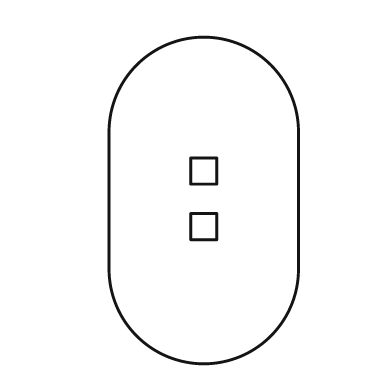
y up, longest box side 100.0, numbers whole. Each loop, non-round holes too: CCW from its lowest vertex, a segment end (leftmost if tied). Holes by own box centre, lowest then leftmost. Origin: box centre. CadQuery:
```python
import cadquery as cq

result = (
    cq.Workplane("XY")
    .moveTo(-29.0, -21.0)
    .threePointArc((0.0, -50.0), (29.0, -21.0))
    .lineTo(29.0, 21.0)
    .threePointArc((0.0, 50.0), (-29.0, 21.0))
    .close()
    .moveTo(-4.0, -12.0)
    .lineTo(4.0, -12.0)
    .lineTo(4.0, -4.0)
    .lineTo(-4.0, -4.0)
    .close()
    .moveTo(-4.0, 5.0)
    .lineTo(4.0, 5.0)
    .lineTo(4.0, 13.0)
    .lineTo(-4.0, 13.0)
    .close()
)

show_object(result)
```